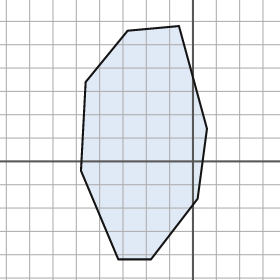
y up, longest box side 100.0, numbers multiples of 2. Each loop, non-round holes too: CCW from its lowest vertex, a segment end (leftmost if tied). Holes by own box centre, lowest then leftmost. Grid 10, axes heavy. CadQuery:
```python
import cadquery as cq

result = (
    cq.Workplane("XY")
    .moveTo(-32.0, -42.0)
    .lineTo(-18.0, -42.0)
    .lineTo(2.0, -16.0)
    .lineTo(6.0, 14.0)
    .lineTo(-6.0, 58.0)
    .lineTo(-28.0, 56.0)
    .lineTo(-46.0, 34.0)
    .lineTo(-48.0, -4.0)
    .close()
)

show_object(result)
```